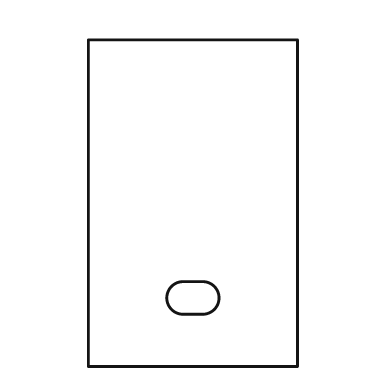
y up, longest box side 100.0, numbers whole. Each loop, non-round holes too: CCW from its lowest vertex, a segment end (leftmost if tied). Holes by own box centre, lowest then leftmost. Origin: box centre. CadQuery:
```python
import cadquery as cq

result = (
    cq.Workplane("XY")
    .moveTo(-32.0, -50.0)
    .lineTo(32.0, -50.0)
    .lineTo(32.0, 50.0)
    .lineTo(-32.0, 50.0)
    .close()
    .moveTo(-3.0, -34.0)
    .lineTo(3.0, -34.0)
    .threePointArc((8.0, -29.0), (3.0, -24.0))
    .lineTo(-3.0, -24.0)
    .threePointArc((-8.0, -29.0), (-3.0, -34.0))
    .close()
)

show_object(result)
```